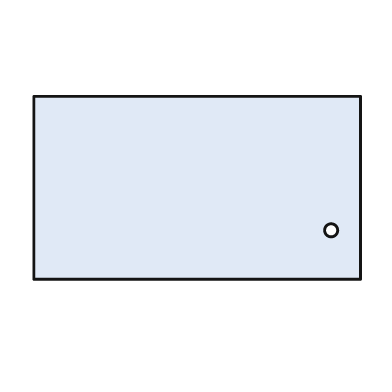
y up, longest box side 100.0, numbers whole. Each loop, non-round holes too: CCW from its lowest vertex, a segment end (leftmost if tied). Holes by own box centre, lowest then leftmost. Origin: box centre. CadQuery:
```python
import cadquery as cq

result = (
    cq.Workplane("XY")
    .moveTo(-50.0, -28.0)
    .lineTo(50.0, -28.0)
    .lineTo(50.0, 28.0)
    .lineTo(-50.0, 28.0)
    .close()
    .moveTo(41.0, -13.0)
    .circle(2.0)
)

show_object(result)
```